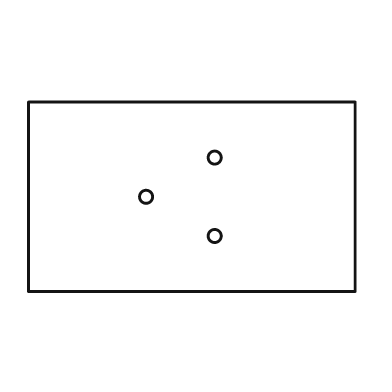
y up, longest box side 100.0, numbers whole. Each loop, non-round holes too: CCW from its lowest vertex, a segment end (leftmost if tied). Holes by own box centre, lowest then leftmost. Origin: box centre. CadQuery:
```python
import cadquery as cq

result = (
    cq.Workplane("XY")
    .moveTo(-50.0, -29.0)
    .lineTo(50.0, -29.0)
    .lineTo(50.0, 29.0)
    .lineTo(-50.0, 29.0)
    .close()
    .moveTo(7.0, -12.0)
    .circle(2.0)
    .moveTo(-14.0, 0.0)
    .circle(2.0)
    .moveTo(7.0, 12.0)
    .circle(2.0)
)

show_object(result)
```